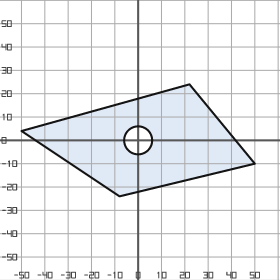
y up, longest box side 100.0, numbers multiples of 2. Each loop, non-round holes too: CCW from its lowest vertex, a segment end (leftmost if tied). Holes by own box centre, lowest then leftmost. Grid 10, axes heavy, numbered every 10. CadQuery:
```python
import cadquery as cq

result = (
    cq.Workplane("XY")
    .moveTo(-8.0, -24.0)
    .lineTo(50.0, -10.0)
    .lineTo(22.0, 24.0)
    .lineTo(-50.0, 4.0)
    .close()
    .moveTo(0.0, 0.0)
    .circle(6.0)
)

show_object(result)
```